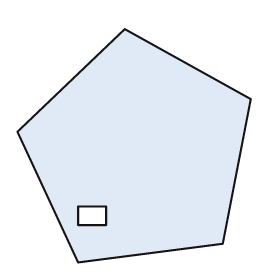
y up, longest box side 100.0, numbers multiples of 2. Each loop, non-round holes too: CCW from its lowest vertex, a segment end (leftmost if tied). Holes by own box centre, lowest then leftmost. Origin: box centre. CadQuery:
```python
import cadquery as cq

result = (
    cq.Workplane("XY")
    .moveTo(-24.0, -50.0)
    .lineTo(38.0, -42.0)
    .lineTo(50.0, 20.0)
    .lineTo(-4.0, 50.0)
    .lineTo(-50.0, 6.0)
    .close()
    .moveTo(-24.0, -34.0)
    .lineTo(-12.0, -34.0)
    .lineTo(-12.0, -26.0)
    .lineTo(-24.0, -26.0)
    .close()
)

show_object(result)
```